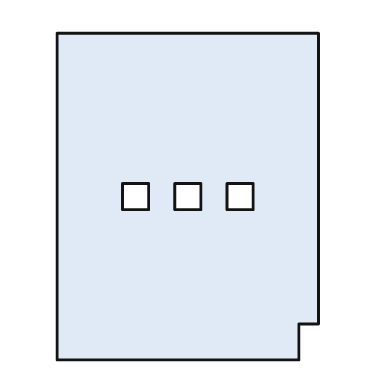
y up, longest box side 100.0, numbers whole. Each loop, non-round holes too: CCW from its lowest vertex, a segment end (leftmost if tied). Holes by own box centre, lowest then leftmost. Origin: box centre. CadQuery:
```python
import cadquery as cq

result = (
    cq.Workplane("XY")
    .moveTo(-40.0, -50.0)
    .lineTo(34.0, -50.0)
    .lineTo(34.0, -39.0)
    .lineTo(40.0, -39.0)
    .lineTo(40.0, 50.0)
    .lineTo(-40.0, 50.0)
    .close()
    .moveTo(-20.0, -4.0)
    .lineTo(-12.0, -4.0)
    .lineTo(-12.0, 4.0)
    .lineTo(-20.0, 4.0)
    .close()
    .moveTo(-4.0, -4.0)
    .lineTo(4.0, -4.0)
    .lineTo(4.0, 4.0)
    .lineTo(-4.0, 4.0)
    .close()
    .moveTo(12.0, -4.0)
    .lineTo(20.0, -4.0)
    .lineTo(20.0, 4.0)
    .lineTo(12.0, 4.0)
    .close()
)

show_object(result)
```